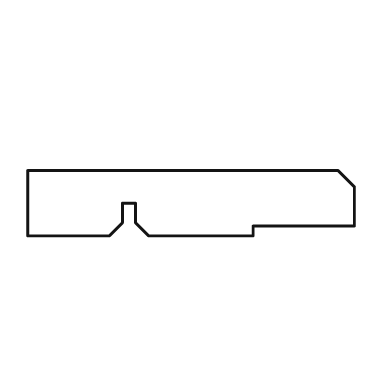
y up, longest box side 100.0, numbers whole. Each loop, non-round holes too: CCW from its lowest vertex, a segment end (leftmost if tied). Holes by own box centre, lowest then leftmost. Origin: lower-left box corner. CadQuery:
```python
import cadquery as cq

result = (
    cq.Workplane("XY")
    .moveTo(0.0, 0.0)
    .lineTo(25.0, 0.0)
    .lineTo(29.0, 4.0)
    .lineTo(29.0, 10.0)
    .lineTo(33.0, 10.0)
    .lineTo(33.0, 4.0)
    .lineTo(37.0, 0.0)
    .lineTo(69.0, 0.0)
    .lineTo(69.0, 3.0)
    .lineTo(100.0, 3.0)
    .lineTo(100.0, 15.0)
    .lineTo(95.0, 20.0)
    .lineTo(0.0, 20.0)
    .close()
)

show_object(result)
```